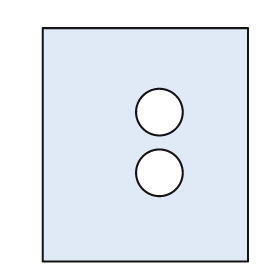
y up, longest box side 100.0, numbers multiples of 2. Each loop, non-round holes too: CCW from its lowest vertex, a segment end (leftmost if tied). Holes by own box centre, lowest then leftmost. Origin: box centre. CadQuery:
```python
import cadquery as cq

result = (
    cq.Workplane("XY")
    .moveTo(-44.0, -50.0)
    .lineTo(44.0, -50.0)
    .lineTo(44.0, 50.0)
    .lineTo(-44.0, 50.0)
    .close()
    .moveTo(6.0, -12.0)
    .circle(10.0)
    .moveTo(6.0, 14.0)
    .circle(10.0)
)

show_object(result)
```